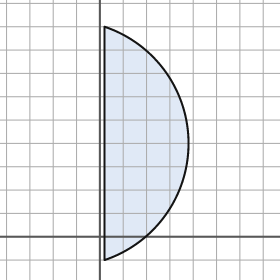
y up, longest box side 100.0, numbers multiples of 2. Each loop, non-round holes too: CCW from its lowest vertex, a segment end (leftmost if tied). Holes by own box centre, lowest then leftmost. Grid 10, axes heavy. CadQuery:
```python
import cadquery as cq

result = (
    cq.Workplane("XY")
    .moveTo(2.0, -10.0)
    .threePointArc((38.0, 40.0), (2.0, 90.0))
    .close()
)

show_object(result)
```